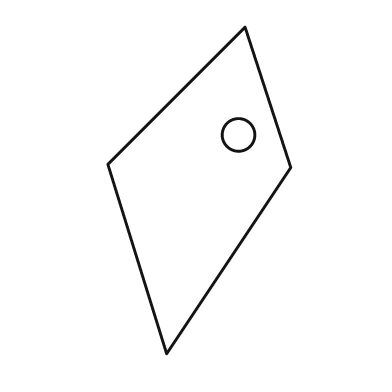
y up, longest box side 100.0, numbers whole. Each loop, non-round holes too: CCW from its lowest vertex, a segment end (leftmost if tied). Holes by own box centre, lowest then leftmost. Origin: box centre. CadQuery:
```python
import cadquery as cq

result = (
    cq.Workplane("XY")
    .moveTo(-10.0, -50.0)
    .lineTo(28.0, 7.0)
    .lineTo(14.0, 50.0)
    .lineTo(-28.0, 8.0)
    .close()
    .moveTo(12.0, 17.0)
    .circle(5.0)
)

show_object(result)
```